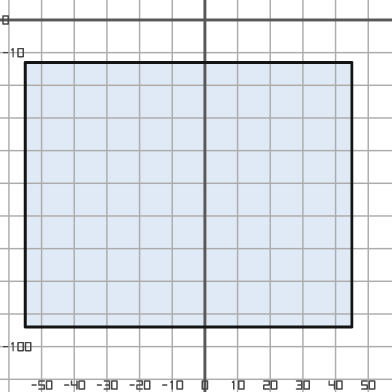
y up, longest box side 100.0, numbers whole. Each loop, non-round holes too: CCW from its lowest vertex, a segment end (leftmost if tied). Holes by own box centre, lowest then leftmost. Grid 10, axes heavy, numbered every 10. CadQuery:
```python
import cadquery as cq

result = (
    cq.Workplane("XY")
    .moveTo(-55.0, -94.0)
    .lineTo(45.0, -94.0)
    .lineTo(45.0, -13.0)
    .lineTo(-55.0, -13.0)
    .close()
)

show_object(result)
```